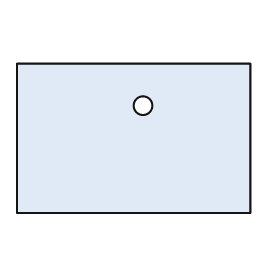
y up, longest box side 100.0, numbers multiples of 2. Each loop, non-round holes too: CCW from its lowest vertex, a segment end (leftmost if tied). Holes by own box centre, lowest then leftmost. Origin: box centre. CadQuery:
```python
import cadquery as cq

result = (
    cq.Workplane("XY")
    .moveTo(-50.0, -32.0)
    .lineTo(50.0, -32.0)
    .lineTo(50.0, 32.0)
    .lineTo(-50.0, 32.0)
    .close()
    .moveTo(4.0, 14.0)
    .circle(4.0)
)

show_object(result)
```